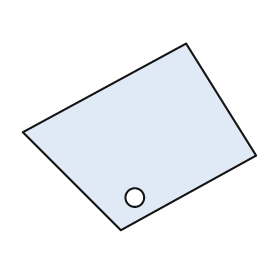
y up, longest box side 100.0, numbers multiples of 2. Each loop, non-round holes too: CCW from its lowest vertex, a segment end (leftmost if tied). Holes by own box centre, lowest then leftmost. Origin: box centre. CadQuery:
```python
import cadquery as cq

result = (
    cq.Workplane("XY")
    .moveTo(-8.0, -40.0)
    .lineTo(50.0, -8.0)
    .lineTo(20.0, 40.0)
    .lineTo(-50.0, 2.0)
    .close()
    .moveTo(-2.0, -26.0)
    .circle(4.0)
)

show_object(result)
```